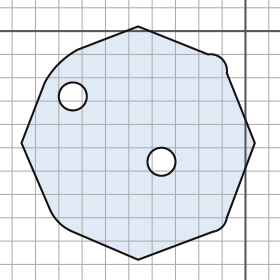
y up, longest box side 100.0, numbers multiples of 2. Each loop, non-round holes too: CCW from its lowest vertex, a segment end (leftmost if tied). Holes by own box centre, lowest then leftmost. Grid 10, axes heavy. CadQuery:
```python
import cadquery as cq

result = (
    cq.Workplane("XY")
    .moveTo(-46.0, -98.0)
    .lineTo(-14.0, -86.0)
    .threePointArc((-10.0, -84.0), (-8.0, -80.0))
    .lineTo(4.0, -48.0)
    .lineTo(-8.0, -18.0)
    .threePointArc((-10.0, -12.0), (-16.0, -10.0))
    .lineTo(-46.0, 2.0)
    .lineTo(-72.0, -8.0)
    .threePointArc((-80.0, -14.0), (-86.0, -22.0))
    .lineTo(-96.0, -48.0)
    .lineTo(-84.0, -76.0)
    .threePointArc((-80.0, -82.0), (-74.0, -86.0))
    .close()
    .moveTo(-36.0, -56.0)
    .circle(6.0)
    .moveTo(-74.0, -28.0)
    .circle(6.0)
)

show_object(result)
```